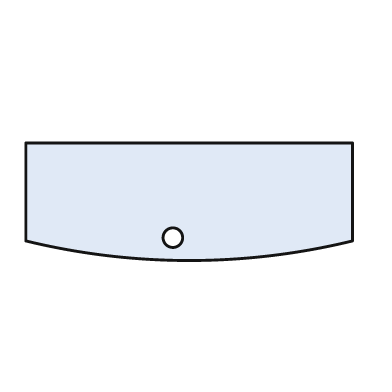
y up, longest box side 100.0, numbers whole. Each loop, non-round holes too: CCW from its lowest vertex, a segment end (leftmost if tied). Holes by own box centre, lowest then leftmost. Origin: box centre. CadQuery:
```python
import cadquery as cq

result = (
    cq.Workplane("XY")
    .moveTo(-50.0, -12.0)
    .threePointArc((0.0, -18.0), (50.0, -12.0))
    .lineTo(50.0, 18.0)
    .lineTo(-50.0, 18.0)
    .close()
    .moveTo(-5.0, -11.0)
    .circle(3.0)
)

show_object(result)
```